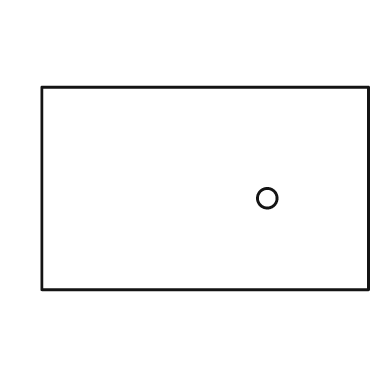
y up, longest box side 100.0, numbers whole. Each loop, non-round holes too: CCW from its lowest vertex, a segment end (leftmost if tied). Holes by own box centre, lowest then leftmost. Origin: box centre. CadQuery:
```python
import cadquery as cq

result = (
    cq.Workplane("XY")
    .moveTo(-50.0, -31.0)
    .lineTo(50.0, -31.0)
    .lineTo(50.0, 31.0)
    .lineTo(-50.0, 31.0)
    .close()
    .moveTo(19.0, -3.0)
    .circle(3.0)
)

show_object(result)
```